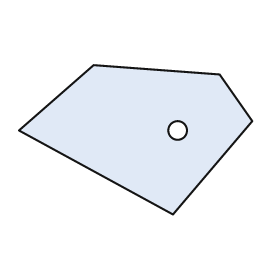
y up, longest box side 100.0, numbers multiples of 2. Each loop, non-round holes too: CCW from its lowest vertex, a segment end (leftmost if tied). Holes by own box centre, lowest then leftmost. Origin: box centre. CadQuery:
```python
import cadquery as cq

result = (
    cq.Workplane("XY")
    .moveTo(16.0, -32.0)
    .lineTo(50.0, 8.0)
    .lineTo(36.0, 28.0)
    .lineTo(-18.0, 32.0)
    .lineTo(-50.0, 4.0)
    .close()
    .moveTo(18.0, 4.0)
    .circle(4.0)
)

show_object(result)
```